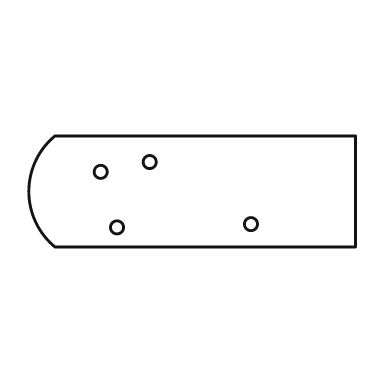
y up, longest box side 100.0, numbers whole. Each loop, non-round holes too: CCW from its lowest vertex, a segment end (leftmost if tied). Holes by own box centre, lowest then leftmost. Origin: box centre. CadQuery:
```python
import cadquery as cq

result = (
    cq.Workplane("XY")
    .moveTo(-42.0, -17.0)
    .lineTo(50.0, -17.0)
    .lineTo(50.0, 17.0)
    .lineTo(-42.0, 17.0)
    .threePointArc((-50.0, 0.0), (-42.0, -17.0))
    .close()
    .moveTo(-23.0, -11.0)
    .circle(2.0)
    .moveTo(18.0, -10.0)
    .circle(2.0)
    .moveTo(-28.0, 6.0)
    .circle(2.0)
    .moveTo(-13.0, 9.0)
    .circle(2.0)
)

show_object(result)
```